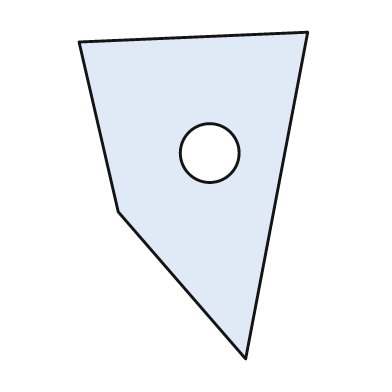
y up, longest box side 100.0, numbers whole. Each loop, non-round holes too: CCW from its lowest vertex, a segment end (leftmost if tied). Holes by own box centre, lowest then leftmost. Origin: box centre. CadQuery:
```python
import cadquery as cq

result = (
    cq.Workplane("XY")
    .moveTo(16.0, -50.0)
    .lineTo(35.0, 50.0)
    .lineTo(-35.0, 47.0)
    .lineTo(-23.0, -5.0)
    .close()
    .moveTo(5.0, 13.0)
    .circle(9.0)
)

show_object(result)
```